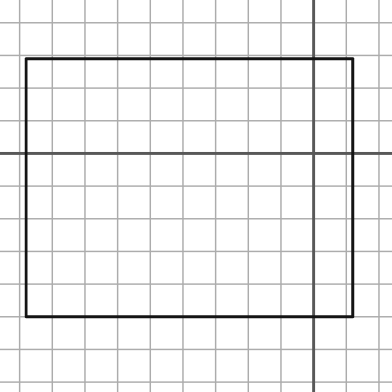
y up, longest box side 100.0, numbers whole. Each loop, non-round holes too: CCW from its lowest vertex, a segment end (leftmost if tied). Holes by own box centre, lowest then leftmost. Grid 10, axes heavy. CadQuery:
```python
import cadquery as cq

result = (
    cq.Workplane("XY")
    .moveTo(-88.0, -50.0)
    .lineTo(12.0, -50.0)
    .lineTo(12.0, 29.0)
    .lineTo(-88.0, 29.0)
    .close()
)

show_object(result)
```